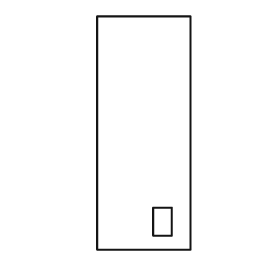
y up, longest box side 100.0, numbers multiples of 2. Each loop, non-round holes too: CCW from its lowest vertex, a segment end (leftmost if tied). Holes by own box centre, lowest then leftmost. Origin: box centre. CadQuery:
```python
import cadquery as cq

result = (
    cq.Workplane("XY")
    .moveTo(-20.0, -50.0)
    .lineTo(20.0, -50.0)
    .lineTo(20.0, 50.0)
    .lineTo(-20.0, 50.0)
    .close()
    .moveTo(4.0, -44.0)
    .lineTo(12.0, -44.0)
    .lineTo(12.0, -32.0)
    .lineTo(4.0, -32.0)
    .close()
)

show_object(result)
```